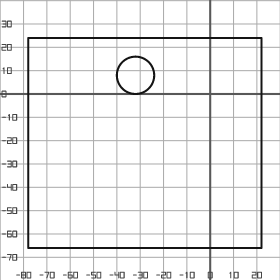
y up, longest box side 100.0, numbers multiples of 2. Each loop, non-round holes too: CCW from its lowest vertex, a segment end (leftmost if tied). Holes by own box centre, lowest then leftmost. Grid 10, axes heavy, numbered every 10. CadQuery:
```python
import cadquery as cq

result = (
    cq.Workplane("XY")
    .moveTo(-78.0, -66.0)
    .lineTo(22.0, -66.0)
    .lineTo(22.0, 24.0)
    .lineTo(-78.0, 24.0)
    .close()
    .moveTo(-32.0, 8.0)
    .circle(8.0)
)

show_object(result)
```